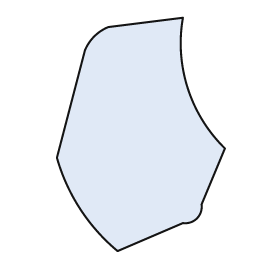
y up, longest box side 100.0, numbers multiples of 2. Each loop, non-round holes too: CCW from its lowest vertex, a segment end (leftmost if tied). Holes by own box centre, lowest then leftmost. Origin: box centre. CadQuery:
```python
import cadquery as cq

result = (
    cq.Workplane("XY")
    .moveTo(-10.0, -50.0)
    .lineTo(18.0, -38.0)
    .threePointArc((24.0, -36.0), (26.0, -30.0))
    .lineTo(36.0, -6.0)
    .threePointArc((20.0, 20.0), (18.0, 50.0))
    .lineTo(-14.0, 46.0)
    .threePointArc((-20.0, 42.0), (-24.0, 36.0))
    .lineTo(-36.0, -10.0)
    .threePointArc((-26.0, -32.0), (-10.0, -50.0))
    .close()
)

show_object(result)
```